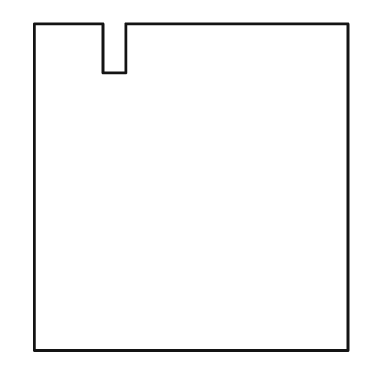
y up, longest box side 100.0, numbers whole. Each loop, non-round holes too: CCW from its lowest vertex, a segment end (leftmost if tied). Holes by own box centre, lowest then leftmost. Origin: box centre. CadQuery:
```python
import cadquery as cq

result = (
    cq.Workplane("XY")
    .moveTo(-48.0, -50.0)
    .lineTo(48.0, -50.0)
    .lineTo(48.0, 50.0)
    .lineTo(-20.0, 50.0)
    .lineTo(-20.0, 35.0)
    .lineTo(-27.0, 35.0)
    .lineTo(-27.0, 50.0)
    .lineTo(-48.0, 50.0)
    .close()
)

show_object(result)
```